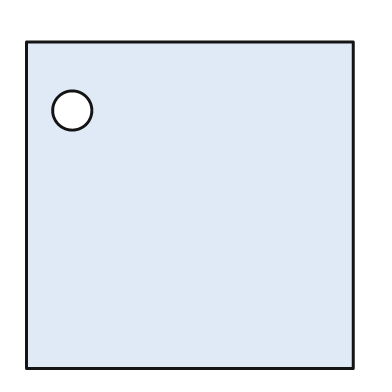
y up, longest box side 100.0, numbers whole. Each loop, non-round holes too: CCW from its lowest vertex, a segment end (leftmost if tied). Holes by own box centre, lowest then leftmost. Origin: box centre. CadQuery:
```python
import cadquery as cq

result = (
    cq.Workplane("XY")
    .moveTo(-50.0, -50.0)
    .lineTo(50.0, -50.0)
    .lineTo(50.0, 50.0)
    .lineTo(-50.0, 50.0)
    .close()
    .moveTo(-36.0, 29.0)
    .circle(6.0)
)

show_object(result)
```